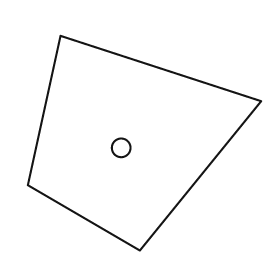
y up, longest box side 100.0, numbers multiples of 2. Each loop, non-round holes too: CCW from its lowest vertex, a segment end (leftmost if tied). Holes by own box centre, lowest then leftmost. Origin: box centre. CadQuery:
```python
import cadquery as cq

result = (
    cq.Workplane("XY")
    .moveTo(-2.0, -46.0)
    .lineTo(50.0, 18.0)
    .lineTo(-36.0, 46.0)
    .lineTo(-50.0, -18.0)
    .close()
    .moveTo(-10.0, -2.0)
    .circle(4.0)
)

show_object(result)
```